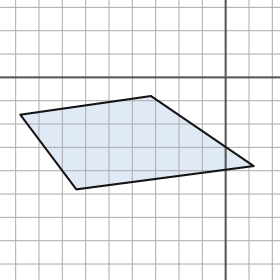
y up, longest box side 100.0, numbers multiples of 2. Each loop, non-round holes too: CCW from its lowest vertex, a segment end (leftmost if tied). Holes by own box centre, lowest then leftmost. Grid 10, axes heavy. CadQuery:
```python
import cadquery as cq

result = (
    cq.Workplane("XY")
    .moveTo(-64.0, -48.0)
    .lineTo(12.0, -38.0)
    .lineTo(-32.0, -8.0)
    .lineTo(-88.0, -16.0)
    .close()
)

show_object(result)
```